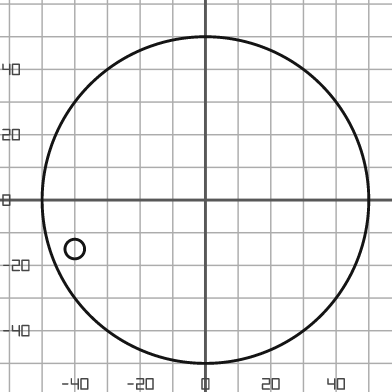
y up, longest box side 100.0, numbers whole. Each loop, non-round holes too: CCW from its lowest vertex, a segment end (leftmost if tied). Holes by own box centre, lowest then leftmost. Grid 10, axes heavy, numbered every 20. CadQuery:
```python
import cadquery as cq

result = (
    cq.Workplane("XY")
    .moveTo(0.0, 0.0)
    .circle(50.0)
    .moveTo(-40.0, -15.0)
    .circle(3.0)
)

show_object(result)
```